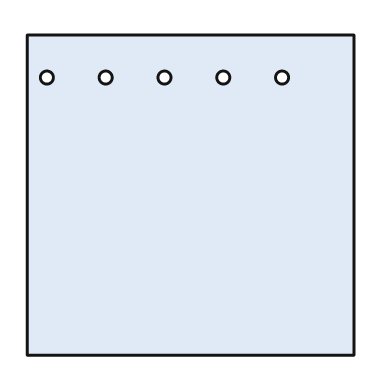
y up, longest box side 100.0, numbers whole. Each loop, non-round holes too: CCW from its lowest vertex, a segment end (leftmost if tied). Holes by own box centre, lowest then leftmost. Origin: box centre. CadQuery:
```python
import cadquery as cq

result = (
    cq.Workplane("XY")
    .moveTo(-50.0, -49.0)
    .lineTo(50.0, -49.0)
    .lineTo(50.0, 49.0)
    .lineTo(-50.0, 49.0)
    .close()
    .moveTo(-44.0, 36.0)
    .circle(2.0)
    .moveTo(-26.0, 36.0)
    .circle(2.0)
    .moveTo(-8.0, 36.0)
    .circle(2.0)
    .moveTo(10.0, 36.0)
    .circle(2.0)
    .moveTo(28.0, 36.0)
    .circle(2.0)
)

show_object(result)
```